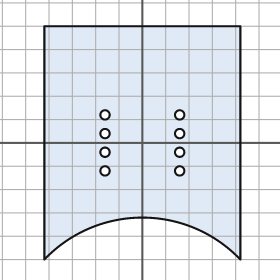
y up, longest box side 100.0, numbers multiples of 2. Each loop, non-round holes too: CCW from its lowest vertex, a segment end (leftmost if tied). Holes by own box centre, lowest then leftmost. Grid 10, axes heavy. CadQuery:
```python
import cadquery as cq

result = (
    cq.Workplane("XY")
    .moveTo(-42.0, -50.0)
    .threePointArc((0.0, -32.0), (42.0, -50.0))
    .lineTo(42.0, 50.0)
    .lineTo(-42.0, 50.0)
    .close()
    .moveTo(-16.0, -12.0)
    .circle(2.0)
    .moveTo(16.0, -12.0)
    .circle(2.0)
    .moveTo(-16.0, -4.0)
    .circle(2.0)
    .moveTo(16.0, -4.0)
    .circle(2.0)
    .moveTo(-16.0, 4.0)
    .circle(2.0)
    .moveTo(16.0, 4.0)
    .circle(2.0)
    .moveTo(-16.0, 12.0)
    .circle(2.0)
    .moveTo(16.0, 12.0)
    .circle(2.0)
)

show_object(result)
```